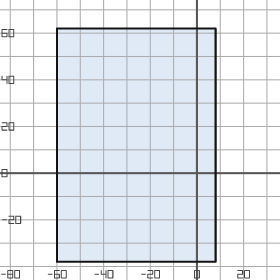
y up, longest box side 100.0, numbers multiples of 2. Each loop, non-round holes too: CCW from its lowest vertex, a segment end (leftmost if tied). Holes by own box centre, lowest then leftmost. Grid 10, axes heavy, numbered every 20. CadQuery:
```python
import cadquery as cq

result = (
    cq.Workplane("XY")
    .moveTo(-60.0, -38.0)
    .lineTo(8.0, -38.0)
    .lineTo(8.0, 62.0)
    .lineTo(-60.0, 62.0)
    .close()
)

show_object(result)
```